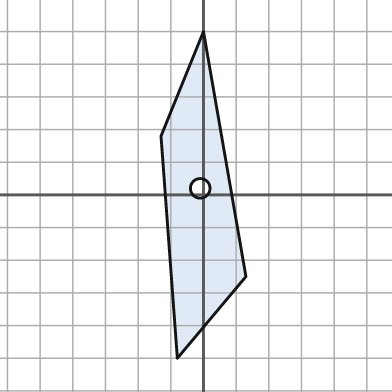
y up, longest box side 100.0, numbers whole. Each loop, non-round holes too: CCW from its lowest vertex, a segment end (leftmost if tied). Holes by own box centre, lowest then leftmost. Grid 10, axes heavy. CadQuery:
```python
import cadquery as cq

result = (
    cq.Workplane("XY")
    .moveTo(-8.0, -50.0)
    .lineTo(13.0, -25.0)
    .lineTo(0.0, 50.0)
    .lineTo(-13.0, 18.0)
    .close()
    .moveTo(-1.0, 2.0)
    .circle(3.0)
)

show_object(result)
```